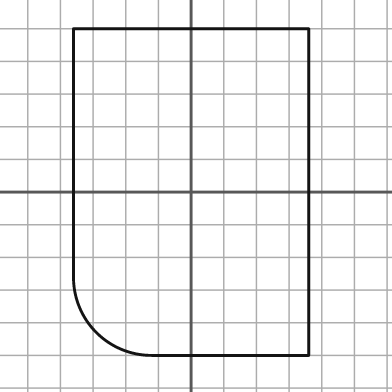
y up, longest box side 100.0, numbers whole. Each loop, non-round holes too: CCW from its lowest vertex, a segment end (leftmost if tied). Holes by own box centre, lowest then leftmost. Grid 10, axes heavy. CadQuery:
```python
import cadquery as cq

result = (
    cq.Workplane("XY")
    .moveTo(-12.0, -50.0)
    .lineTo(36.0, -50.0)
    .lineTo(36.0, 50.0)
    .lineTo(-36.0, 50.0)
    .lineTo(-36.0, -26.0)
    .threePointArc((-29.0, -43.0), (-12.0, -50.0))
    .close()
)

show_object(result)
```